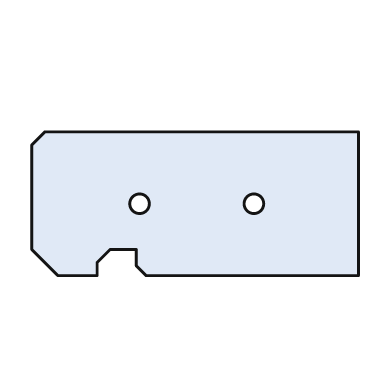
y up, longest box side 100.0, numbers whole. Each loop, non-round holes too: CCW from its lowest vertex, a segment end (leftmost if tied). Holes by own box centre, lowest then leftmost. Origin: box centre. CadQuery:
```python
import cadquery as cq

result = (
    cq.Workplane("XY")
    .moveTo(-42.0, -22.0)
    .lineTo(-30.0, -22.0)
    .lineTo(-30.0, -18.0)
    .lineTo(-26.0, -14.0)
    .lineTo(-18.0, -14.0)
    .lineTo(-18.0, -19.0)
    .lineTo(-15.0, -22.0)
    .lineTo(50.0, -22.0)
    .lineTo(50.0, 22.0)
    .lineTo(-46.0, 22.0)
    .lineTo(-50.0, 18.0)
    .lineTo(-50.0, -14.0)
    .close()
    .moveTo(-17.0, 0.0)
    .circle(3.0)
    .moveTo(18.0, 0.0)
    .circle(3.0)
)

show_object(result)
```